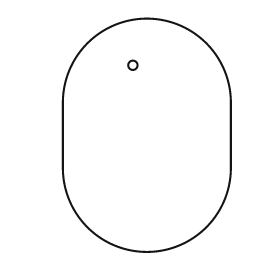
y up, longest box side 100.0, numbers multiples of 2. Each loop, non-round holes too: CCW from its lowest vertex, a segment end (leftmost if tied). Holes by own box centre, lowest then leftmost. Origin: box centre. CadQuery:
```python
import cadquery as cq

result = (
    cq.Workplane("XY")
    .moveTo(-36.0, -14.0)
    .threePointArc((0.0, -50.0), (36.0, -14.0))
    .lineTo(36.0, 14.0)
    .threePointArc((0.0, 50.0), (-36.0, 14.0))
    .close()
    .moveTo(-6.0, 30.0)
    .circle(2.0)
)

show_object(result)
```